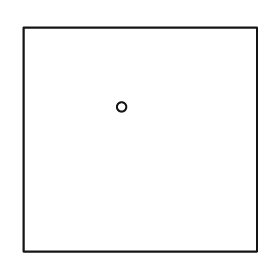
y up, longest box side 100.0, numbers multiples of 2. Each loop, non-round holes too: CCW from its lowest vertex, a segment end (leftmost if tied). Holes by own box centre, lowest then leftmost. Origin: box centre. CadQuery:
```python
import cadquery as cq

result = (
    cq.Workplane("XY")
    .moveTo(-50.0, -48.0)
    .lineTo(50.0, -48.0)
    .lineTo(50.0, 48.0)
    .lineTo(-50.0, 48.0)
    .close()
    .moveTo(-8.0, 14.0)
    .circle(2.0)
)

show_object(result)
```